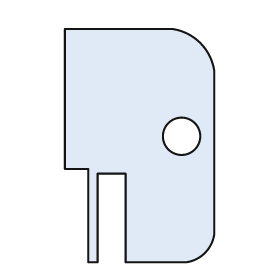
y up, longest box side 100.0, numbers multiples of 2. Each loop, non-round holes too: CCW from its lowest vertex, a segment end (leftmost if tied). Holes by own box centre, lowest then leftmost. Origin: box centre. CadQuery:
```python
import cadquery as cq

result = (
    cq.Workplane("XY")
    .moveTo(-22.0, -50.0)
    .lineTo(-18.0, -50.0)
    .lineTo(-18.0, -12.0)
    .lineTo(-6.0, -12.0)
    .lineTo(-6.0, -50.0)
    .lineTo(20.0, -50.0)
    .threePointArc((28.0, -46.0), (32.0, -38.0))
    .lineTo(32.0, 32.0)
    .threePointArc((26.0, 44.0), (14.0, 50.0))
    .lineTo(-32.0, 50.0)
    .lineTo(-32.0, -10.0)
    .lineTo(-22.0, -10.0)
    .close()
    .moveTo(18.0, 4.0)
    .circle(8.0)
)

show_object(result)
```